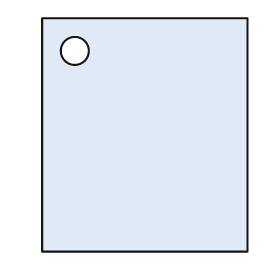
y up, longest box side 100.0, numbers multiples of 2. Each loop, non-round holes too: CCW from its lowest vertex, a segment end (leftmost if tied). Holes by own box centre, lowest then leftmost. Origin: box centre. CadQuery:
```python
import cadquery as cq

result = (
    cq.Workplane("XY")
    .moveTo(-44.0, -50.0)
    .lineTo(44.0, -50.0)
    .lineTo(44.0, 50.0)
    .lineTo(-44.0, 50.0)
    .close()
    .moveTo(-30.0, 36.0)
    .circle(6.0)
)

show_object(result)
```